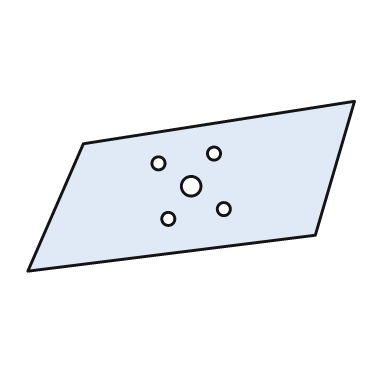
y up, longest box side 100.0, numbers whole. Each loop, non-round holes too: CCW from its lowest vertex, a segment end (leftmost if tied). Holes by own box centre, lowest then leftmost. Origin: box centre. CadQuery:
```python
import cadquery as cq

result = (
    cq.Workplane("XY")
    .moveTo(-50.0, -26.0)
    .lineTo(38.0, -15.0)
    .lineTo(50.0, 26.0)
    .lineTo(-33.0, 13.0)
    .close()
    .moveTo(-7.0, -10.0)
    .circle(2.0)
    .moveTo(10.0, -7.0)
    .circle(2.0)
    .moveTo(0.0, 0.0)
    .circle(3.0)
    .moveTo(-10.0, 7.0)
    .circle(2.0)
    .moveTo(7.0, 10.0)
    .circle(2.0)
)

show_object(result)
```